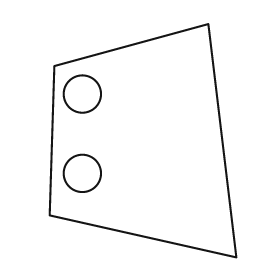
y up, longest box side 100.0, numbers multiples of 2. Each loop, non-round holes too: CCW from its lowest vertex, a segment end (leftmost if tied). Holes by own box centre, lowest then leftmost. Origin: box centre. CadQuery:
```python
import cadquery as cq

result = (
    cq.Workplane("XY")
    .moveTo(40.0, -50.0)
    .lineTo(28.0, 50.0)
    .lineTo(-38.0, 32.0)
    .lineTo(-40.0, -32.0)
    .close()
    .moveTo(-26.0, -14.0)
    .circle(8.0)
    .moveTo(-26.0, 20.0)
    .circle(8.0)
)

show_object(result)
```